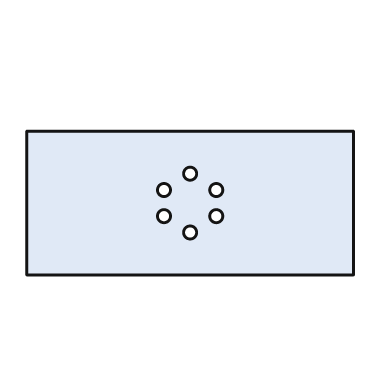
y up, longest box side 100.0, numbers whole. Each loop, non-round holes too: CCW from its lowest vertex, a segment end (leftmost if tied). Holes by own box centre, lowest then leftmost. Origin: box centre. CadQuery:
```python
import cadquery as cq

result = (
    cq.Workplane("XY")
    .moveTo(-50.0, -22.0)
    .lineTo(50.0, -22.0)
    .lineTo(50.0, 22.0)
    .lineTo(-50.0, 22.0)
    .close()
    .moveTo(0.0, -9.0)
    .circle(2.0)
    .moveTo(-8.0, -4.0)
    .circle(2.0)
    .moveTo(8.0, -4.0)
    .circle(2.0)
    .moveTo(-8.0, 4.0)
    .circle(2.0)
    .moveTo(8.0, 4.0)
    .circle(2.0)
    .moveTo(0.0, 9.0)
    .circle(2.0)
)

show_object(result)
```